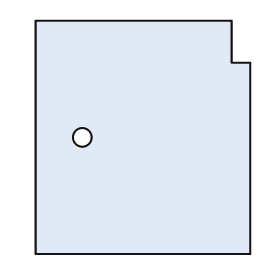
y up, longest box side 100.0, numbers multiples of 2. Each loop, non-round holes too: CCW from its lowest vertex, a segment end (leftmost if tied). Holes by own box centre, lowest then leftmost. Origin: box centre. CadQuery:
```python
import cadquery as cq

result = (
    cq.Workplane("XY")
    .moveTo(-46.0, -50.0)
    .lineTo(46.0, -50.0)
    .lineTo(46.0, 32.0)
    .lineTo(38.0, 32.0)
    .lineTo(38.0, 50.0)
    .lineTo(-46.0, 50.0)
    .close()
    .moveTo(-26.0, 0.0)
    .circle(4.0)
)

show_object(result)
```